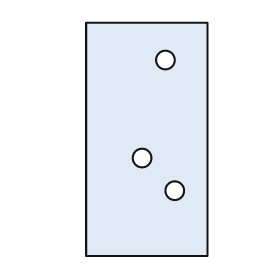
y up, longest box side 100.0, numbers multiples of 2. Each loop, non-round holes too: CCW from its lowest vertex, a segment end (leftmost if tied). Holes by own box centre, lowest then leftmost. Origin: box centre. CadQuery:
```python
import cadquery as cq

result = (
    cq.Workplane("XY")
    .moveTo(-26.0, -50.0)
    .lineTo(26.0, -50.0)
    .lineTo(26.0, 50.0)
    .lineTo(-26.0, 50.0)
    .close()
    .moveTo(12.0, -22.0)
    .circle(4.0)
    .moveTo(-2.0, -8.0)
    .circle(4.0)
    .moveTo(8.0, 34.0)
    .circle(4.0)
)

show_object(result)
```